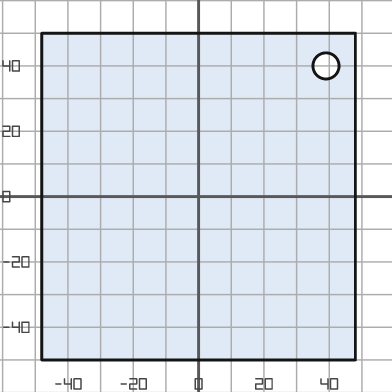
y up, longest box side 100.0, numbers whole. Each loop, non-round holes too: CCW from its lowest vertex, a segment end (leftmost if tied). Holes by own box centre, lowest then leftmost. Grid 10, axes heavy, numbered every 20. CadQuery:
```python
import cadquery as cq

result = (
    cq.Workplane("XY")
    .moveTo(-48.0, -50.0)
    .lineTo(48.0, -50.0)
    .lineTo(48.0, 50.0)
    .lineTo(-48.0, 50.0)
    .close()
    .moveTo(39.0, 40.0)
    .circle(4.0)
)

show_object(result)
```